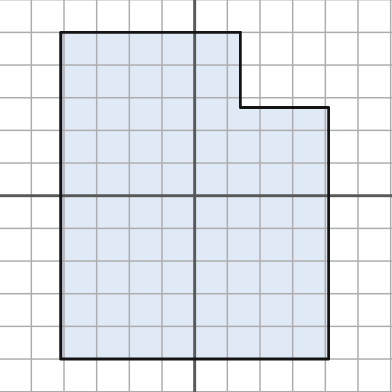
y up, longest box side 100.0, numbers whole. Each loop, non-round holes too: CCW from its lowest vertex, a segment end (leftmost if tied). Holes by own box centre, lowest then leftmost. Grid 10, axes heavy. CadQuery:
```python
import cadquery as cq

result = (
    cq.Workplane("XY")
    .moveTo(-41.0, -50.0)
    .lineTo(41.0, -50.0)
    .lineTo(41.0, 27.0)
    .lineTo(14.0, 27.0)
    .lineTo(14.0, 50.0)
    .lineTo(-41.0, 50.0)
    .close()
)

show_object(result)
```